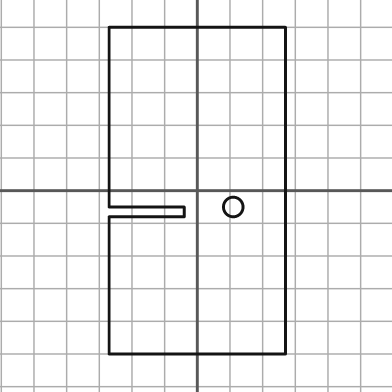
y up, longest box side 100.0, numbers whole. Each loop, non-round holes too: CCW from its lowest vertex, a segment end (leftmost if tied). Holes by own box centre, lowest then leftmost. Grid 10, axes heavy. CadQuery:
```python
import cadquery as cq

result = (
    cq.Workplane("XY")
    .moveTo(-27.0, -50.0)
    .lineTo(27.0, -50.0)
    .lineTo(27.0, 50.0)
    .lineTo(-27.0, 50.0)
    .lineTo(-27.0, -5.0)
    .lineTo(-4.0, -5.0)
    .lineTo(-4.0, -8.0)
    .lineTo(-27.0, -8.0)
    .close()
    .moveTo(11.0, -5.0)
    .circle(3.0)
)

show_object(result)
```